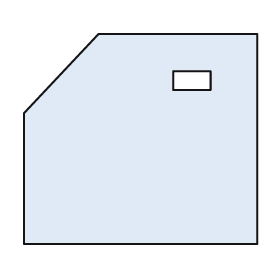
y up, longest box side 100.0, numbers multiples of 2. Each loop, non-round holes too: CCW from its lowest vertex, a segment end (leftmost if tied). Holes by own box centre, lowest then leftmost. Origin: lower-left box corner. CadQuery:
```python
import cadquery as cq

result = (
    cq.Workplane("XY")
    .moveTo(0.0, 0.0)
    .lineTo(100.0, 0.0)
    .lineTo(100.0, 90.0)
    .lineTo(32.0, 90.0)
    .lineTo(0.0, 56.0)
    .close()
    .moveTo(64.0, 66.0)
    .lineTo(80.0, 66.0)
    .lineTo(80.0, 74.0)
    .lineTo(64.0, 74.0)
    .close()
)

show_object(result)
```